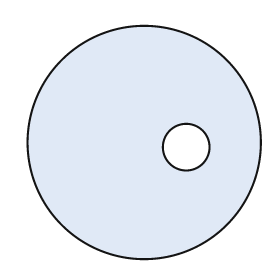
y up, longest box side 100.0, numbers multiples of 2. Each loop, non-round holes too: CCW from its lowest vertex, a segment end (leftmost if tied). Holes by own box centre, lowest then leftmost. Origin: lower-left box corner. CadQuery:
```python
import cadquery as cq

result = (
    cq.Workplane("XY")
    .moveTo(50.0, 50.0)
    .circle(50.0)
    .moveTo(68.0, 48.0)
    .circle(10.0)
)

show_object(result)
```